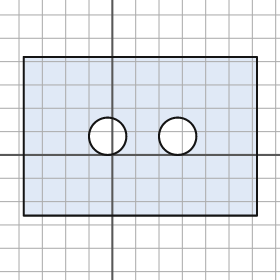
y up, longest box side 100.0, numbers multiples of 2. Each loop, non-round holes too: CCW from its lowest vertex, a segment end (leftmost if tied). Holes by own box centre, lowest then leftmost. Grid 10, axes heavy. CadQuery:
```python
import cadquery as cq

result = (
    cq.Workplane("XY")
    .moveTo(-38.0, -26.0)
    .lineTo(62.0, -26.0)
    .lineTo(62.0, 42.0)
    .lineTo(-38.0, 42.0)
    .close()
    .moveTo(-2.0, 8.0)
    .circle(8.0)
    .moveTo(28.0, 8.0)
    .circle(8.0)
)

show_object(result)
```